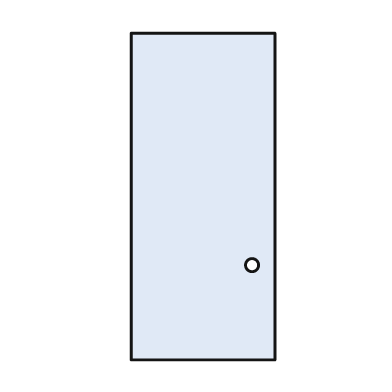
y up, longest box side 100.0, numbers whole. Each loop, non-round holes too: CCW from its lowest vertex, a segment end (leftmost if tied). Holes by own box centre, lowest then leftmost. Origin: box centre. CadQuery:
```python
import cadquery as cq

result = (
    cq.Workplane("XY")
    .moveTo(-22.0, -50.0)
    .lineTo(22.0, -50.0)
    .lineTo(22.0, 50.0)
    .lineTo(-22.0, 50.0)
    .close()
    .moveTo(15.0, -21.0)
    .circle(2.0)
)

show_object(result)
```